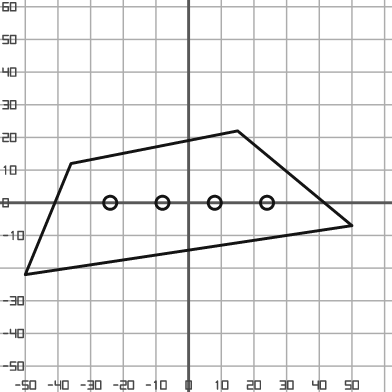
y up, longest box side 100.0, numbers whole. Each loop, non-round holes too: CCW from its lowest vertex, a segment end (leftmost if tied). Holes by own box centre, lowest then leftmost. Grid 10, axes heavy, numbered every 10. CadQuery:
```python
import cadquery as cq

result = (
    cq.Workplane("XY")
    .moveTo(-50.0, -22.0)
    .lineTo(50.0, -7.0)
    .lineTo(15.0, 22.0)
    .lineTo(-36.0, 12.0)
    .close()
    .moveTo(-24.0, 0.0)
    .circle(2.0)
    .moveTo(-8.0, 0.0)
    .circle(2.0)
    .moveTo(8.0, 0.0)
    .circle(2.0)
    .moveTo(24.0, 0.0)
    .circle(2.0)
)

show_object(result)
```